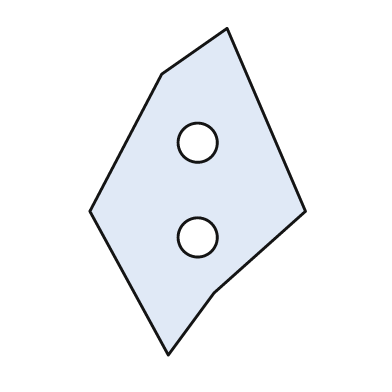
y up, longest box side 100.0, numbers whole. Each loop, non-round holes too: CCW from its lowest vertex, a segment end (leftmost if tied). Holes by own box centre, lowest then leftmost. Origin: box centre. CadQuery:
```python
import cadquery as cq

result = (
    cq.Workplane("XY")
    .moveTo(-9.0, -50.0)
    .lineTo(5.0, -31.0)
    .lineTo(33.0, -6.0)
    .lineTo(9.0, 50.0)
    .lineTo(-11.0, 36.0)
    .lineTo(-33.0, -6.0)
    .close()
    .moveTo(0.0, -14.0)
    .circle(6.0)
    .moveTo(0.0, 15.0)
    .circle(6.0)
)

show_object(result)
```